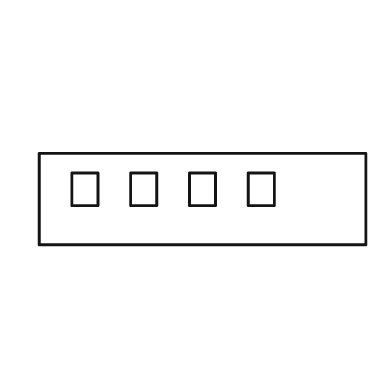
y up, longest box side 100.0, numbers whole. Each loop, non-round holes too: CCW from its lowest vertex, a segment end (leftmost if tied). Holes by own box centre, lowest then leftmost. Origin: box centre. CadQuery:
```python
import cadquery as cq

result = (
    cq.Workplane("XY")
    .moveTo(-50.0, -14.0)
    .lineTo(50.0, -14.0)
    .lineTo(50.0, 14.0)
    .lineTo(-50.0, 14.0)
    .close()
    .moveTo(-40.0, -2.0)
    .lineTo(-32.0, -2.0)
    .lineTo(-32.0, 8.0)
    .lineTo(-40.0, 8.0)
    .close()
    .moveTo(-22.0, -2.0)
    .lineTo(-14.0, -2.0)
    .lineTo(-14.0, 8.0)
    .lineTo(-22.0, 8.0)
    .close()
    .moveTo(-4.0, -2.0)
    .lineTo(4.0, -2.0)
    .lineTo(4.0, 8.0)
    .lineTo(-4.0, 8.0)
    .close()
    .moveTo(14.0, -2.0)
    .lineTo(22.0, -2.0)
    .lineTo(22.0, 8.0)
    .lineTo(14.0, 8.0)
    .close()
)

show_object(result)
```